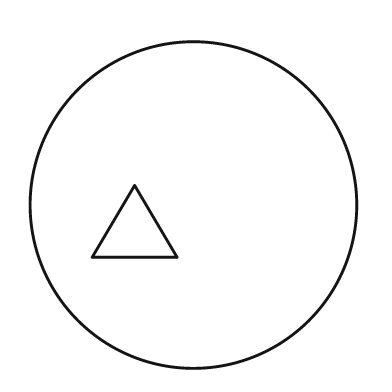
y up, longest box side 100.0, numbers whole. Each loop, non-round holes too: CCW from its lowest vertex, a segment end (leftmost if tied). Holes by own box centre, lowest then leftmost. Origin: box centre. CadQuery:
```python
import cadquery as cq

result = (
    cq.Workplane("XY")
    .moveTo(0.0, 0.0)
    .circle(50.0)
    .moveTo(-31.0, -16.0)
    .lineTo(-5.0, -16.0)
    .lineTo(-18.0, 6.0)
    .close()
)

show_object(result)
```